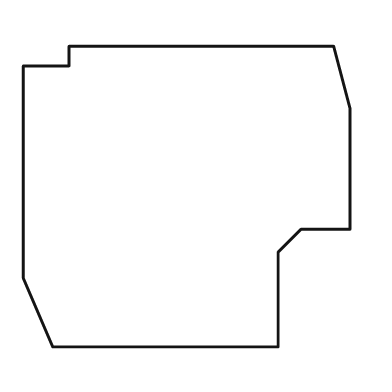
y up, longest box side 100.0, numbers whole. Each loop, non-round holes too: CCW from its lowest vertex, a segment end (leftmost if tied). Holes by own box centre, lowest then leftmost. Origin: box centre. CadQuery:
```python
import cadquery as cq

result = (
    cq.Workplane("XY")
    .moveTo(-41.0, -46.0)
    .lineTo(28.0, -46.0)
    .lineTo(28.0, -17.0)
    .lineTo(35.0, -10.0)
    .lineTo(50.0, -10.0)
    .lineTo(50.0, 27.0)
    .lineTo(45.0, 46.0)
    .lineTo(-36.0, 46.0)
    .lineTo(-36.0, 40.0)
    .lineTo(-50.0, 40.0)
    .lineTo(-50.0, -25.0)
    .close()
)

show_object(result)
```